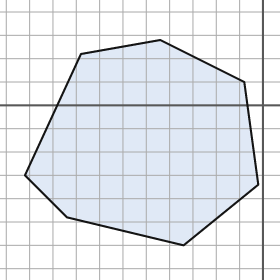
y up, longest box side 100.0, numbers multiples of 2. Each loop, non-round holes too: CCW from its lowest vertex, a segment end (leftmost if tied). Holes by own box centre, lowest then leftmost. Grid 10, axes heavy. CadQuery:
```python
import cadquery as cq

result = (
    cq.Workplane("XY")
    .moveTo(-34.0, -60.0)
    .lineTo(-2.0, -34.0)
    .lineTo(-8.0, 10.0)
    .lineTo(-44.0, 28.0)
    .lineTo(-78.0, 22.0)
    .lineTo(-102.0, -30.0)
    .lineTo(-84.0, -48.0)
    .close()
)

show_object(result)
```